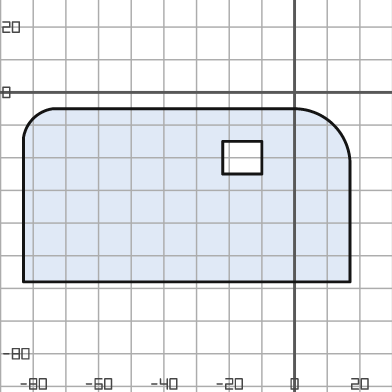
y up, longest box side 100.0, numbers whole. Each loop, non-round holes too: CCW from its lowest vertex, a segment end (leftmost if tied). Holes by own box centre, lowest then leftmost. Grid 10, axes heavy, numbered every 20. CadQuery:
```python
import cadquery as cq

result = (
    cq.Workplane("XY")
    .moveTo(-83.0, -58.0)
    .lineTo(17.0, -58.0)
    .lineTo(17.0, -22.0)
    .threePointArc((12.0, -10.0), (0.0, -5.0))
    .lineTo(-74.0, -5.0)
    .threePointArc((-80.0, -8.0), (-83.0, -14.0))
    .close()
    .moveTo(-22.0, -25.0)
    .lineTo(-10.0, -25.0)
    .lineTo(-10.0, -15.0)
    .lineTo(-22.0, -15.0)
    .close()
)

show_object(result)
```